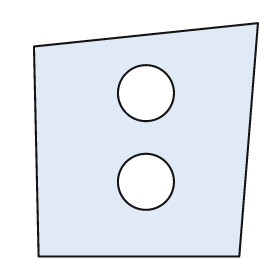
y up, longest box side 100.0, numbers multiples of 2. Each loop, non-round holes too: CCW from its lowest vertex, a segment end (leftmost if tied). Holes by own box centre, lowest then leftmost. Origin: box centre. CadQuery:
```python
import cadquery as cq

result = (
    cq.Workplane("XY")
    .moveTo(-46.0, -50.0)
    .lineTo(40.0, -50.0)
    .lineTo(48.0, 50.0)
    .lineTo(-48.0, 40.0)
    .close()
    .moveTo(0.0, -18.0)
    .circle(12.0)
    .moveTo(0.0, 20.0)
    .circle(12.0)
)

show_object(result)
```